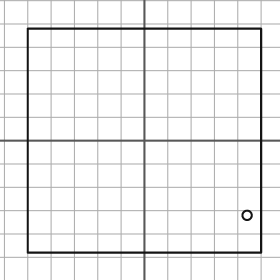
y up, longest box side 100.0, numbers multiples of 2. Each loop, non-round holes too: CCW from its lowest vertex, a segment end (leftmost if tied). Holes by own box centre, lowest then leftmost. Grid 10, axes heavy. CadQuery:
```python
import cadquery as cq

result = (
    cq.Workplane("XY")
    .moveTo(-50.0, -48.0)
    .lineTo(50.0, -48.0)
    .lineTo(50.0, 48.0)
    .lineTo(-50.0, 48.0)
    .close()
    .moveTo(44.0, -32.0)
    .circle(2.0)
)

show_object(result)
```